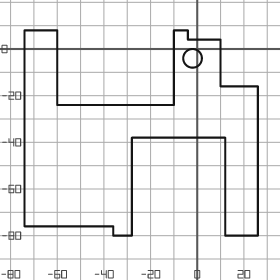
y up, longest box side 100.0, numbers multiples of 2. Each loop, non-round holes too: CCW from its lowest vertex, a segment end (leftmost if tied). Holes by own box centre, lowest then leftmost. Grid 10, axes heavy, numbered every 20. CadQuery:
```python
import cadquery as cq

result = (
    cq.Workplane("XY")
    .moveTo(-36.0, -80.0)
    .lineTo(-28.0, -80.0)
    .lineTo(-28.0, -38.0)
    .lineTo(12.0, -38.0)
    .lineTo(12.0, -80.0)
    .lineTo(26.0, -80.0)
    .lineTo(26.0, -16.0)
    .lineTo(10.0, -16.0)
    .lineTo(10.0, 4.0)
    .lineTo(-4.0, 4.0)
    .lineTo(-4.0, 8.0)
    .lineTo(-10.0, 8.0)
    .lineTo(-10.0, -24.0)
    .lineTo(-60.0, -24.0)
    .lineTo(-60.0, 8.0)
    .lineTo(-74.0, 8.0)
    .lineTo(-74.0, -76.0)
    .lineTo(-36.0, -76.0)
    .close()
    .moveTo(-2.0, -4.0)
    .circle(4.0)
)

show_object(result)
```